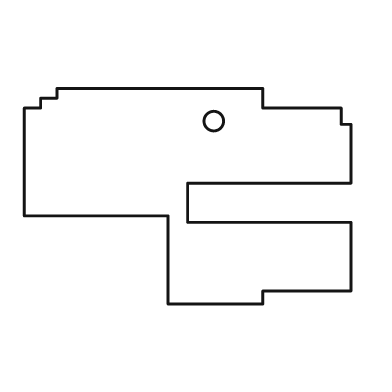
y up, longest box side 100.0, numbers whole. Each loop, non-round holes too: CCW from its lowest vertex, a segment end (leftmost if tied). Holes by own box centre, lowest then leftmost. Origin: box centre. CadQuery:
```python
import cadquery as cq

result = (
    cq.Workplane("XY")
    .moveTo(-6.0, -33.0)
    .lineTo(23.0, -33.0)
    .lineTo(23.0, -29.0)
    .lineTo(50.0, -29.0)
    .lineTo(50.0, -8.0)
    .lineTo(0.0, -8.0)
    .lineTo(0.0, 4.0)
    .lineTo(50.0, 4.0)
    .lineTo(50.0, 22.0)
    .lineTo(47.0, 22.0)
    .lineTo(47.0, 27.0)
    .lineTo(23.0, 27.0)
    .lineTo(23.0, 33.0)
    .lineTo(-40.0, 33.0)
    .lineTo(-40.0, 30.0)
    .lineTo(-45.0, 30.0)
    .lineTo(-45.0, 27.0)
    .lineTo(-50.0, 27.0)
    .lineTo(-50.0, -6.0)
    .lineTo(-6.0, -6.0)
    .close()
    .moveTo(8.0, 23.0)
    .circle(3.0)
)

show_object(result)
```